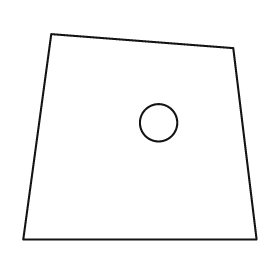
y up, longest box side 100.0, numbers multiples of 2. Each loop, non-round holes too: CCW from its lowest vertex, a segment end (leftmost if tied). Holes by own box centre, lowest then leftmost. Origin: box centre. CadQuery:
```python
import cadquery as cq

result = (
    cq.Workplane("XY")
    .moveTo(-50.0, -44.0)
    .lineTo(50.0, -44.0)
    .lineTo(40.0, 38.0)
    .lineTo(-38.0, 44.0)
    .close()
    .moveTo(8.0, 6.0)
    .circle(8.0)
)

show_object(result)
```